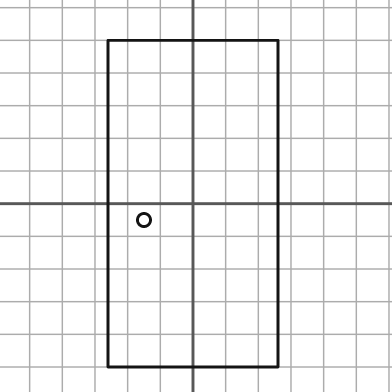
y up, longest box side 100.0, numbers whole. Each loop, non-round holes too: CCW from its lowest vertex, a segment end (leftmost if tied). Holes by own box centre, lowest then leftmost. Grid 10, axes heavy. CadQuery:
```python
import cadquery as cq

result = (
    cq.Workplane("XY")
    .moveTo(-26.0, -50.0)
    .lineTo(26.0, -50.0)
    .lineTo(26.0, 50.0)
    .lineTo(-26.0, 50.0)
    .close()
    .moveTo(-15.0, -5.0)
    .circle(2.0)
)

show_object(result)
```